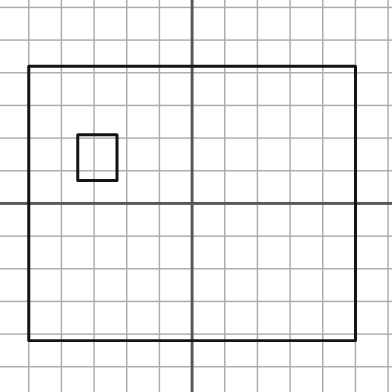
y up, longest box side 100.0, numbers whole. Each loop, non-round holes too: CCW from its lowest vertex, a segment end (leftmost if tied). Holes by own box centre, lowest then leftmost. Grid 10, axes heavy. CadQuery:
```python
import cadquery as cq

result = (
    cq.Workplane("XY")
    .moveTo(-50.0, -42.0)
    .lineTo(50.0, -42.0)
    .lineTo(50.0, 42.0)
    .lineTo(-50.0, 42.0)
    .close()
    .moveTo(-35.0, 7.0)
    .lineTo(-23.0, 7.0)
    .lineTo(-23.0, 21.0)
    .lineTo(-35.0, 21.0)
    .close()
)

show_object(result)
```